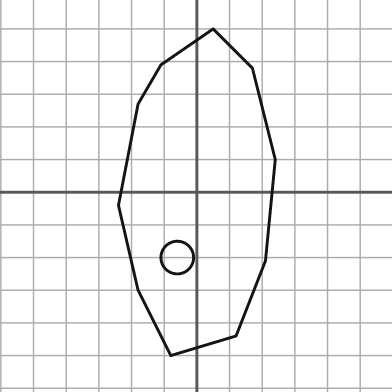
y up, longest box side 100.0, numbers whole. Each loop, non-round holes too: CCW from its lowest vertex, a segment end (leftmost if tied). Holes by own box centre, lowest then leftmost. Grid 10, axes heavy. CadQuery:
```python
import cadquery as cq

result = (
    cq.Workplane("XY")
    .moveTo(-8.0, -50.0)
    .lineTo(12.0, -44.0)
    .lineTo(21.0, -21.0)
    .lineTo(24.0, 10.0)
    .lineTo(17.0, 38.0)
    .lineTo(5.0, 50.0)
    .lineTo(-11.0, 39.0)
    .lineTo(-18.0, 27.0)
    .lineTo(-24.0, -4.0)
    .lineTo(-18.0, -30.0)
    .close()
    .moveTo(-6.0, -20.0)
    .circle(5.0)
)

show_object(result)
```